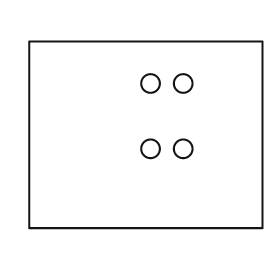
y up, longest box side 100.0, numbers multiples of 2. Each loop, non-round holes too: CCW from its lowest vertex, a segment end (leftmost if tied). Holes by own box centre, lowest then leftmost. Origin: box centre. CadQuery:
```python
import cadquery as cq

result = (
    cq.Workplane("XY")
    .moveTo(-50.0, -40.0)
    .lineTo(50.0, -40.0)
    .lineTo(50.0, 40.0)
    .lineTo(-50.0, 40.0)
    .close()
    .moveTo(2.0, -6.0)
    .circle(4.0)
    .moveTo(16.0, -6.0)
    .circle(4.0)
    .moveTo(2.0, 22.0)
    .circle(4.0)
    .moveTo(16.0, 22.0)
    .circle(4.0)
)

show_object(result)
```